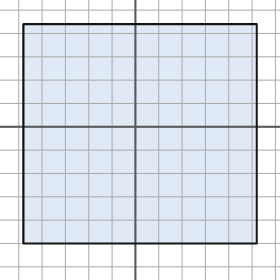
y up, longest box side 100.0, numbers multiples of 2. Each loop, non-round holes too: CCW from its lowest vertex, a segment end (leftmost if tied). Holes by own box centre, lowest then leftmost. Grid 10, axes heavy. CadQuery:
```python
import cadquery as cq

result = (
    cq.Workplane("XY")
    .moveTo(-48.0, -50.0)
    .lineTo(52.0, -50.0)
    .lineTo(52.0, 44.0)
    .lineTo(-48.0, 44.0)
    .close()
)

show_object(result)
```